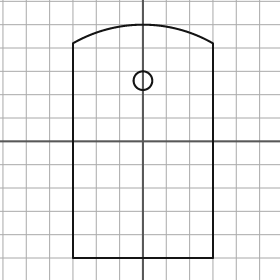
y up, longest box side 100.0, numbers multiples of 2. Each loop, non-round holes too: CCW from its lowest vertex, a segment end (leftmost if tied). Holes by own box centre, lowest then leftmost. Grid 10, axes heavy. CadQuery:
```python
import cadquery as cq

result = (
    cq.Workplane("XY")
    .moveTo(-30.0, -50.0)
    .lineTo(30.0, -50.0)
    .lineTo(30.0, 42.0)
    .threePointArc((0.0, 50.0), (-30.0, 42.0))
    .close()
    .moveTo(0.0, 26.0)
    .circle(4.0)
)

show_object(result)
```